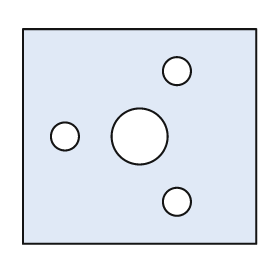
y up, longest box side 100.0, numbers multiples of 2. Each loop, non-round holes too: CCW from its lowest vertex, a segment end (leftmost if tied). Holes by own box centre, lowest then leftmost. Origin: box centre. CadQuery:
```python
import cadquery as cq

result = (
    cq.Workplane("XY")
    .moveTo(-50.0, -46.0)
    .lineTo(50.0, -46.0)
    .lineTo(50.0, 46.0)
    .lineTo(-50.0, 46.0)
    .close()
    .moveTo(16.0, -28.0)
    .circle(6.0)
    .moveTo(-32.0, 0.0)
    .circle(6.0)
    .moveTo(0.0, 0.0)
    .circle(12.0)
    .moveTo(16.0, 28.0)
    .circle(6.0)
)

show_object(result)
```